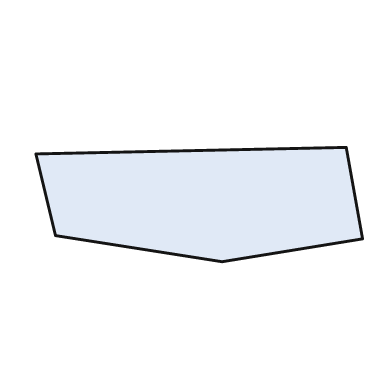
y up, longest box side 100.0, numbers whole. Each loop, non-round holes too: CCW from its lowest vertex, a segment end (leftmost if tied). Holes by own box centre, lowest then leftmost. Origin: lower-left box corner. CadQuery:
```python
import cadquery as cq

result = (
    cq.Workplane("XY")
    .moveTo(57.0, 0.0)
    .lineTo(100.0, 7.0)
    .lineTo(95.0, 35.0)
    .lineTo(0.0, 33.0)
    .lineTo(6.0, 8.0)
    .close()
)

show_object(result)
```